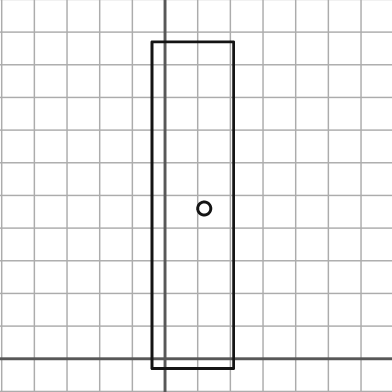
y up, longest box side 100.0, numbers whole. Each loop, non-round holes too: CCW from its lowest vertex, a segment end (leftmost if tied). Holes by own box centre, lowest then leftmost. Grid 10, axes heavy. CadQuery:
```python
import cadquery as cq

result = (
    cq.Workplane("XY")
    .moveTo(-4.0, -3.0)
    .lineTo(21.0, -3.0)
    .lineTo(21.0, 97.0)
    .lineTo(-4.0, 97.0)
    .close()
    .moveTo(12.0, 46.0)
    .circle(2.0)
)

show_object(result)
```